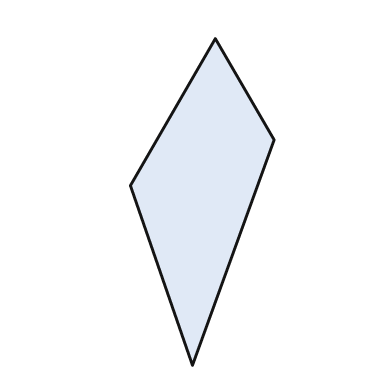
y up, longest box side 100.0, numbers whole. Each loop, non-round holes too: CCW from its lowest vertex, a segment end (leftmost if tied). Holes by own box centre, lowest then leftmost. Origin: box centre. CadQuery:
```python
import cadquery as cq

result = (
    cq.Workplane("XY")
    .moveTo(-3.0, -50.0)
    .lineTo(22.0, 19.0)
    .lineTo(4.0, 50.0)
    .lineTo(-22.0, 5.0)
    .close()
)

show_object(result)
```